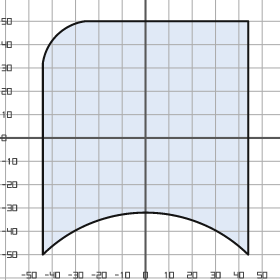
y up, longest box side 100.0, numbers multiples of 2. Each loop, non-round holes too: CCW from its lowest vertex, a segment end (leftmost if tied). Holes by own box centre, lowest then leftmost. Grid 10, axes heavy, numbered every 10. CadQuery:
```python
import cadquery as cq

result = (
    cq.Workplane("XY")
    .moveTo(-44.0, -50.0)
    .threePointArc((0.0, -32.0), (44.0, -50.0))
    .lineTo(44.0, 50.0)
    .lineTo(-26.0, 50.0)
    .threePointArc((-38.0, 44.0), (-44.0, 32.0))
    .close()
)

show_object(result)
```